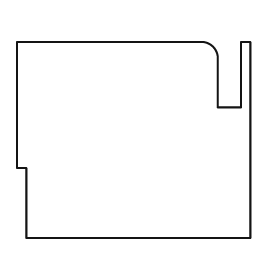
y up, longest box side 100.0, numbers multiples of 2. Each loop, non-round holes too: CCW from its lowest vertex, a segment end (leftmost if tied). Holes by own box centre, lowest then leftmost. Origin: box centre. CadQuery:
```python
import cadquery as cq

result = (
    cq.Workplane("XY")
    .moveTo(-46.0, -42.0)
    .lineTo(50.0, -42.0)
    .lineTo(50.0, 42.0)
    .lineTo(46.0, 42.0)
    .lineTo(46.0, 14.0)
    .lineTo(36.0, 14.0)
    .lineTo(36.0, 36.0)
    .threePointArc((34.0, 40.0), (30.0, 42.0))
    .lineTo(-50.0, 42.0)
    .lineTo(-50.0, -12.0)
    .lineTo(-46.0, -12.0)
    .close()
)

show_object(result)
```